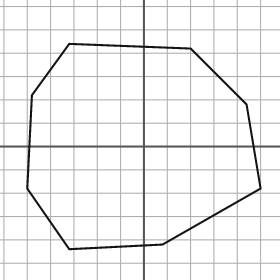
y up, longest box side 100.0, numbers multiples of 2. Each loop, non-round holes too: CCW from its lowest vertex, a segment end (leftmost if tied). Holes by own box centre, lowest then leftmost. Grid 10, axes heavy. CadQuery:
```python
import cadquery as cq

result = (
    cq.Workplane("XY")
    .moveTo(-32.0, -44.0)
    .lineTo(8.0, -42.0)
    .lineTo(50.0, -18.0)
    .lineTo(44.0, 18.0)
    .lineTo(20.0, 42.0)
    .lineTo(-32.0, 44.0)
    .lineTo(-48.0, 22.0)
    .lineTo(-50.0, -18.0)
    .close()
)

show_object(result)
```